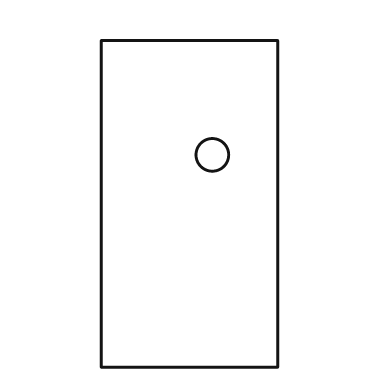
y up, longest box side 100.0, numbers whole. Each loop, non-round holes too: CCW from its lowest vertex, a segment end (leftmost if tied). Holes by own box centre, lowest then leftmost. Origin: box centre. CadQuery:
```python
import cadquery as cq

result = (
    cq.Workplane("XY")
    .moveTo(-27.0, -50.0)
    .lineTo(27.0, -50.0)
    .lineTo(27.0, 50.0)
    .lineTo(-27.0, 50.0)
    .close()
    .moveTo(7.0, 15.0)
    .circle(5.0)
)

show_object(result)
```